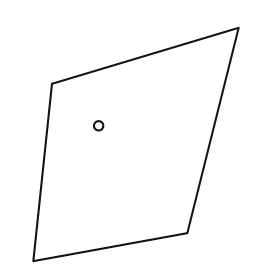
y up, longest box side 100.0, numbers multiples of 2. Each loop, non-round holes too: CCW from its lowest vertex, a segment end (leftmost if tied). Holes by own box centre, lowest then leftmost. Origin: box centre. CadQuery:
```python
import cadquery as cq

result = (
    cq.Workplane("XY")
    .moveTo(-44.0, -50.0)
    .lineTo(22.0, -38.0)
    .lineTo(44.0, 50.0)
    .lineTo(-36.0, 26.0)
    .close()
    .moveTo(-16.0, 8.0)
    .circle(2.0)
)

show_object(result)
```